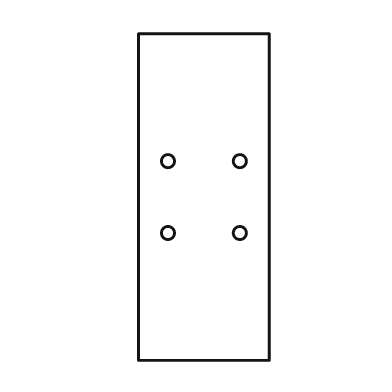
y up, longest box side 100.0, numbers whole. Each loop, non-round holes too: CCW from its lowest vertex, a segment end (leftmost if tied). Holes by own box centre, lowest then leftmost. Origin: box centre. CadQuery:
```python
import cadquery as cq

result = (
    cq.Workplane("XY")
    .moveTo(-20.0, -50.0)
    .lineTo(20.0, -50.0)
    .lineTo(20.0, 50.0)
    .lineTo(-20.0, 50.0)
    .close()
    .moveTo(-11.0, -11.0)
    .circle(2.0)
    .moveTo(11.0, -11.0)
    .circle(2.0)
    .moveTo(-11.0, 11.0)
    .circle(2.0)
    .moveTo(11.0, 11.0)
    .circle(2.0)
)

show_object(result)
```